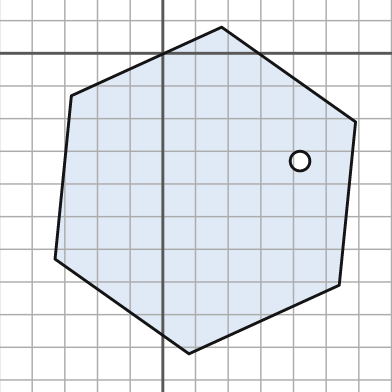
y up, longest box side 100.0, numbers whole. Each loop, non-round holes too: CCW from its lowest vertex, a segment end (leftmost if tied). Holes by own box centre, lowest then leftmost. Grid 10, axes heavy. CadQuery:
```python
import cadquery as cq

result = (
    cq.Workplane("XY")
    .moveTo(8.0, -92.0)
    .lineTo(54.0, -71.0)
    .lineTo(59.0, -21.0)
    .lineTo(18.0, 8.0)
    .lineTo(-28.0, -13.0)
    .lineTo(-33.0, -63.0)
    .close()
    .moveTo(42.0, -33.0)
    .circle(3.0)
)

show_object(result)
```